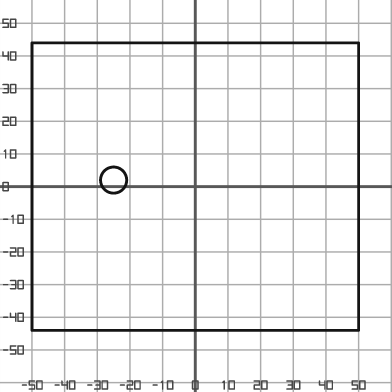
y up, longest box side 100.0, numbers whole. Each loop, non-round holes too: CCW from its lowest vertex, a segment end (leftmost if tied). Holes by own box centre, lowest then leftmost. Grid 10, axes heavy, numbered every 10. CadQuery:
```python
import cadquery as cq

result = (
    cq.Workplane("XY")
    .moveTo(-50.0, -44.0)
    .lineTo(50.0, -44.0)
    .lineTo(50.0, 44.0)
    .lineTo(-50.0, 44.0)
    .close()
    .moveTo(-25.0, 2.0)
    .circle(4.0)
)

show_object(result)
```